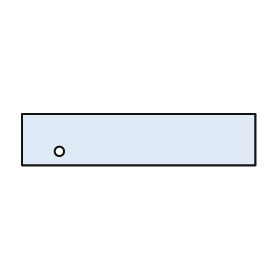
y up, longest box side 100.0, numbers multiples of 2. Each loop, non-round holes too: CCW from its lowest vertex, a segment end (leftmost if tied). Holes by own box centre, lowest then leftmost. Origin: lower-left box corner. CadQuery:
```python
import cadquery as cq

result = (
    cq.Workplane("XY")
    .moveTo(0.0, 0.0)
    .lineTo(100.0, 0.0)
    .lineTo(100.0, 22.0)
    .lineTo(0.0, 22.0)
    .close()
    .moveTo(16.0, 6.0)
    .circle(2.0)
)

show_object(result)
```